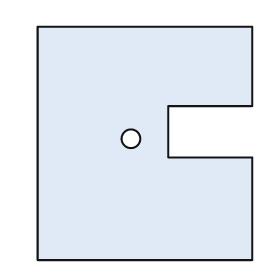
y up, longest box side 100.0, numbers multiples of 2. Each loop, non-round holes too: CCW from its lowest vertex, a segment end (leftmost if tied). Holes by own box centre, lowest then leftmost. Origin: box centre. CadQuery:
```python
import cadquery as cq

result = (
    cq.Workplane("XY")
    .moveTo(-46.0, -50.0)
    .lineTo(46.0, -50.0)
    .lineTo(46.0, -6.0)
    .lineTo(10.0, -6.0)
    .lineTo(10.0, 16.0)
    .lineTo(46.0, 16.0)
    .lineTo(46.0, 50.0)
    .lineTo(-46.0, 50.0)
    .close()
    .moveTo(-6.0, 2.0)
    .circle(4.0)
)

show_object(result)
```